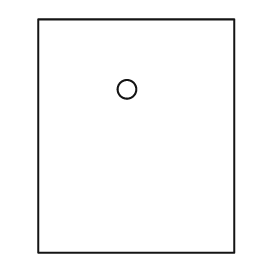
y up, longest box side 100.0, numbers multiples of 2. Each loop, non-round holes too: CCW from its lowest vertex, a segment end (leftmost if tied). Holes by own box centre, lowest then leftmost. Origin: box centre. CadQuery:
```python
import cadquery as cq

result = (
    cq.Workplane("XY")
    .moveTo(-42.0, -50.0)
    .lineTo(42.0, -50.0)
    .lineTo(42.0, 50.0)
    .lineTo(-42.0, 50.0)
    .close()
    .moveTo(-4.0, 20.0)
    .circle(4.0)
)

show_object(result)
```